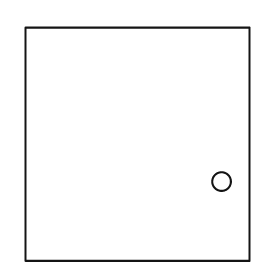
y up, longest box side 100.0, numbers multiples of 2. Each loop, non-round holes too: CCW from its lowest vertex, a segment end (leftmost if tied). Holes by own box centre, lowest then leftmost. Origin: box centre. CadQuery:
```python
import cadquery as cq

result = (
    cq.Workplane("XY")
    .moveTo(-48.0, -50.0)
    .lineTo(48.0, -50.0)
    .lineTo(48.0, 50.0)
    .lineTo(-48.0, 50.0)
    .close()
    .moveTo(36.0, -16.0)
    .circle(4.0)
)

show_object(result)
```